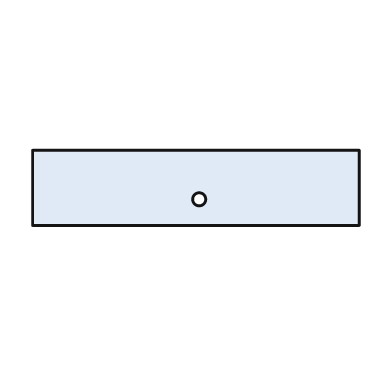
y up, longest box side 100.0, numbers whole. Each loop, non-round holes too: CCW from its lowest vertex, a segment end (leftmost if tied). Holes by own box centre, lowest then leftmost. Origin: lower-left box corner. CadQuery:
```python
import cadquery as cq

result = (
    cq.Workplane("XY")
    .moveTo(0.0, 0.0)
    .lineTo(100.0, 0.0)
    .lineTo(100.0, 23.0)
    .lineTo(0.0, 23.0)
    .close()
    .moveTo(51.0, 8.0)
    .circle(2.0)
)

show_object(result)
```